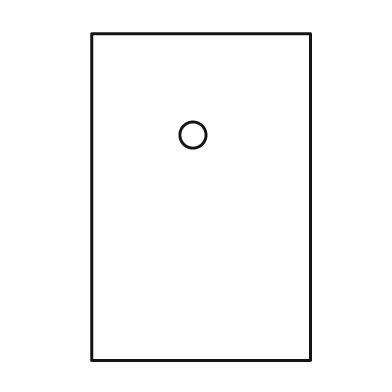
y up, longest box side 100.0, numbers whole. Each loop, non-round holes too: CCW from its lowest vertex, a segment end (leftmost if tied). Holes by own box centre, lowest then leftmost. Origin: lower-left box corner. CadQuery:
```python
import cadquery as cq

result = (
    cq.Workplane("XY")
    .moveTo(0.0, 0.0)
    .lineTo(67.0, 0.0)
    .lineTo(67.0, 100.0)
    .lineTo(0.0, 100.0)
    .close()
    .moveTo(31.0, 69.0)
    .circle(4.0)
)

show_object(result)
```